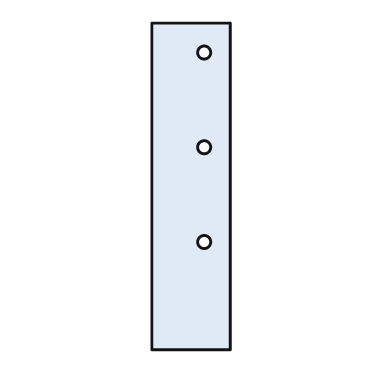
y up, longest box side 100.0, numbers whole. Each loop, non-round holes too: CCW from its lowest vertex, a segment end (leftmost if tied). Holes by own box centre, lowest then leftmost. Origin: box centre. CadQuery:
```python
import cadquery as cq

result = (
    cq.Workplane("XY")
    .moveTo(-12.0, -50.0)
    .lineTo(12.0, -50.0)
    .lineTo(12.0, 50.0)
    .lineTo(-12.0, 50.0)
    .close()
    .moveTo(4.0, -17.0)
    .circle(2.0)
    .moveTo(4.0, 12.0)
    .circle(2.0)
    .moveTo(4.0, 41.0)
    .circle(2.0)
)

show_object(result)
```